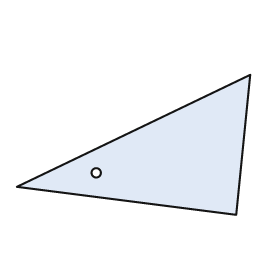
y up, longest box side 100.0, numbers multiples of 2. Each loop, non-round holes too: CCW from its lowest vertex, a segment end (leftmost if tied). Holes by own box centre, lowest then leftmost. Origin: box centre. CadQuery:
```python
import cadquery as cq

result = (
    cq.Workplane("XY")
    .moveTo(44.0, -30.0)
    .lineTo(50.0, 30.0)
    .lineTo(-50.0, -18.0)
    .close()
    .moveTo(-16.0, -12.0)
    .circle(2.0)
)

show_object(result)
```